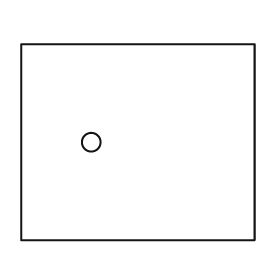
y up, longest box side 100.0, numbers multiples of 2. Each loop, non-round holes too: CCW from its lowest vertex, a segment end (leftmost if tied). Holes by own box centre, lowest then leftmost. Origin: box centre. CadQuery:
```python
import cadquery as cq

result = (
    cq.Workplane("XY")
    .moveTo(-50.0, -42.0)
    .lineTo(50.0, -42.0)
    .lineTo(50.0, 42.0)
    .lineTo(-50.0, 42.0)
    .close()
    .moveTo(-20.0, 0.0)
    .circle(4.0)
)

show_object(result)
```